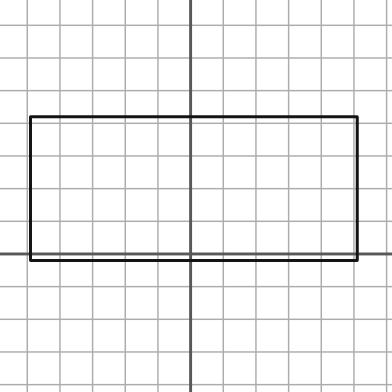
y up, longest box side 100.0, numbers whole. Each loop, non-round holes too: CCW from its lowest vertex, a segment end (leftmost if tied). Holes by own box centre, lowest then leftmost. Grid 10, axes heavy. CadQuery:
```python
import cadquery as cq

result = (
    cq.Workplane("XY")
    .moveTo(-49.0, -2.0)
    .lineTo(51.0, -2.0)
    .lineTo(51.0, 42.0)
    .lineTo(-49.0, 42.0)
    .close()
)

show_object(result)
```